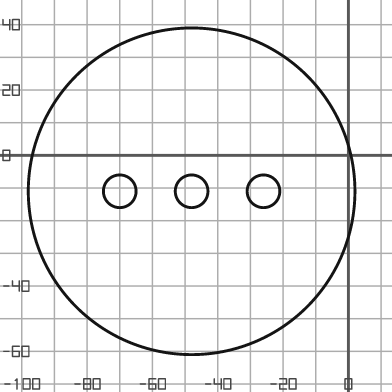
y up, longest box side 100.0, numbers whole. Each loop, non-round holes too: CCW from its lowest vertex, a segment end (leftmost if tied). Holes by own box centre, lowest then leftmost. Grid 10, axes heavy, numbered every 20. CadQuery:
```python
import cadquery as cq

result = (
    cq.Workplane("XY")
    .moveTo(-48.0, -11.0)
    .circle(50.0)
    .moveTo(-70.0, -11.0)
    .circle(5.0)
    .moveTo(-48.0, -11.0)
    .circle(5.0)
    .moveTo(-26.0, -11.0)
    .circle(5.0)
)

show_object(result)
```